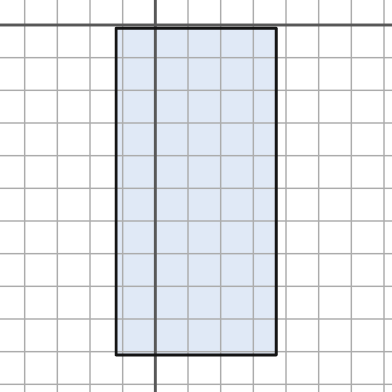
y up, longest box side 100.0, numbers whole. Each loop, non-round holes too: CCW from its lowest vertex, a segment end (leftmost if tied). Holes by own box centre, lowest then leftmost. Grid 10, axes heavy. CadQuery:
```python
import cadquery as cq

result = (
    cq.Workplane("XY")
    .moveTo(-12.0, -101.0)
    .lineTo(37.0, -101.0)
    .lineTo(37.0, -1.0)
    .lineTo(-12.0, -1.0)
    .close()
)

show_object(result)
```